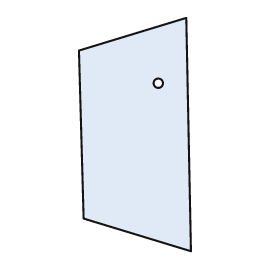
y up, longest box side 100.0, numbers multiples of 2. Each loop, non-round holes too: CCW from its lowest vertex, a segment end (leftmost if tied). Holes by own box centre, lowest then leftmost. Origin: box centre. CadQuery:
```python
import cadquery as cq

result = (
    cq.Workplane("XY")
    .moveTo(24.0, -50.0)
    .lineTo(22.0, 50.0)
    .lineTo(-24.0, 36.0)
    .lineTo(-22.0, -36.0)
    .close()
    .moveTo(10.0, 22.0)
    .circle(2.0)
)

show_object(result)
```